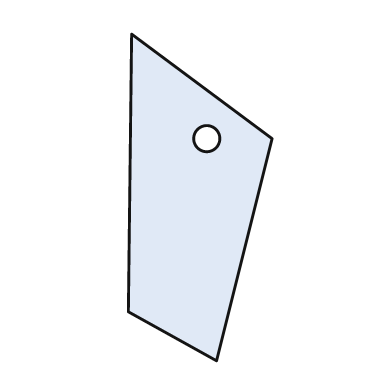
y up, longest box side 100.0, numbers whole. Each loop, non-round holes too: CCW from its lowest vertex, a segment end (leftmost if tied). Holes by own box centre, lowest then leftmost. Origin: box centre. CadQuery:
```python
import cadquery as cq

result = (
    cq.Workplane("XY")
    .moveTo(5.0, -50.0)
    .lineTo(22.0, 18.0)
    .lineTo(-21.0, 50.0)
    .lineTo(-22.0, -35.0)
    .close()
    .moveTo(2.0, 18.0)
    .circle(4.0)
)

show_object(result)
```